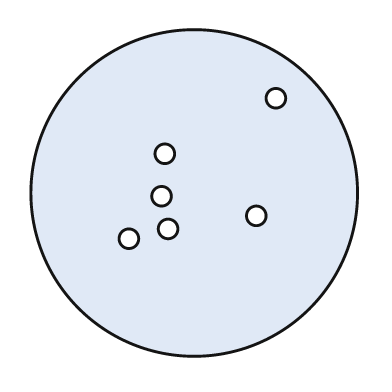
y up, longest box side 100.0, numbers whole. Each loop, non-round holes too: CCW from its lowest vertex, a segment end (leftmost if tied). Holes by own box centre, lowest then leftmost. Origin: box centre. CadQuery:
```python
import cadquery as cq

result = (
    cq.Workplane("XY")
    .moveTo(0.0, 0.0)
    .circle(50.0)
    .moveTo(-20.0, -14.0)
    .circle(3.0)
    .moveTo(-8.0, -11.0)
    .circle(3.0)
    .moveTo(19.0, -7.0)
    .circle(3.0)
    .moveTo(-10.0, -1.0)
    .circle(3.0)
    .moveTo(-9.0, 12.0)
    .circle(3.0)
    .moveTo(25.0, 29.0)
    .circle(3.0)
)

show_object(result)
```